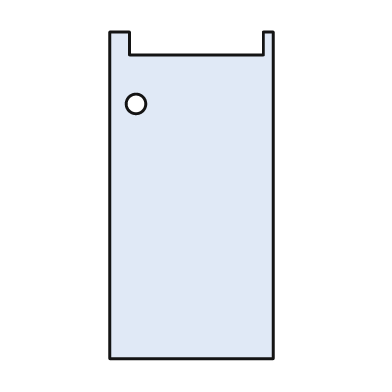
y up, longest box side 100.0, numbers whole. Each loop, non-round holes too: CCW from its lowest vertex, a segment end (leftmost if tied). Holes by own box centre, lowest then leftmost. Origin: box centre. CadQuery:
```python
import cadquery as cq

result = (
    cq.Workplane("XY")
    .moveTo(-25.0, -50.0)
    .lineTo(25.0, -50.0)
    .lineTo(25.0, 50.0)
    .lineTo(22.0, 50.0)
    .lineTo(22.0, 43.0)
    .lineTo(-19.0, 43.0)
    .lineTo(-19.0, 50.0)
    .lineTo(-25.0, 50.0)
    .close()
    .moveTo(-17.0, 28.0)
    .circle(3.0)
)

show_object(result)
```